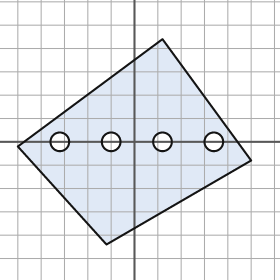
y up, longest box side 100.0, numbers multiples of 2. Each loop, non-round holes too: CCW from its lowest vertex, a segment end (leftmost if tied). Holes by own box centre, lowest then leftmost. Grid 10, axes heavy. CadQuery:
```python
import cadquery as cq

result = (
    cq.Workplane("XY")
    .moveTo(-12.0, -44.0)
    .lineTo(50.0, -8.0)
    .lineTo(12.0, 44.0)
    .lineTo(-50.0, -2.0)
    .close()
    .moveTo(-32.0, 0.0)
    .circle(4.0)
    .moveTo(-10.0, 0.0)
    .circle(4.0)
    .moveTo(12.0, 0.0)
    .circle(4.0)
    .moveTo(34.0, 0.0)
    .circle(4.0)
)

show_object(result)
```